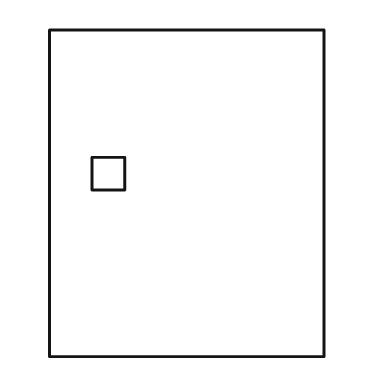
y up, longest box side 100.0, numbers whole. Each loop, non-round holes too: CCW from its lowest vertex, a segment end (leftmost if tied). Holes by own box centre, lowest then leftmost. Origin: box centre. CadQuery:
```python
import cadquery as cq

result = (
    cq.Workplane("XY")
    .moveTo(-42.0, -50.0)
    .lineTo(42.0, -50.0)
    .lineTo(42.0, 50.0)
    .lineTo(-42.0, 50.0)
    .close()
    .moveTo(-29.0, 1.0)
    .lineTo(-19.0, 1.0)
    .lineTo(-19.0, 11.0)
    .lineTo(-29.0, 11.0)
    .close()
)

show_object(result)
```